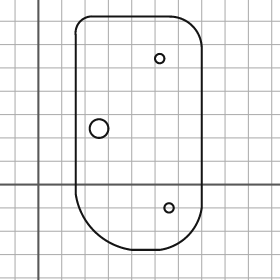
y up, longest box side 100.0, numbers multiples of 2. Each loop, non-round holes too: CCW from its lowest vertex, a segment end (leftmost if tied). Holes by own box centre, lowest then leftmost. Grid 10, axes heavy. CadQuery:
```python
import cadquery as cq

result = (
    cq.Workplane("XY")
    .moveTo(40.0, -28.0)
    .lineTo(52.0, -28.0)
    .threePointArc((64.0, -22.0), (70.0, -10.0))
    .lineTo(70.0, 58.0)
    .threePointArc((66.0, 68.0), (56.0, 72.0))
    .lineTo(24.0, 72.0)
    .threePointArc((18.0, 70.0), (16.0, 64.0))
    .lineTo(16.0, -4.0)
    .threePointArc((24.0, -20.0), (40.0, -28.0))
    .close()
    .moveTo(56.0, -10.0)
    .circle(2.0)
    .moveTo(26.0, 24.0)
    .circle(4.0)
    .moveTo(52.0, 54.0)
    .circle(2.0)
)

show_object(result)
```